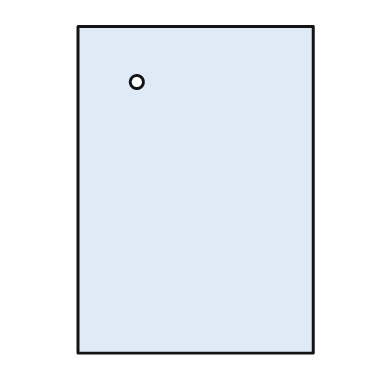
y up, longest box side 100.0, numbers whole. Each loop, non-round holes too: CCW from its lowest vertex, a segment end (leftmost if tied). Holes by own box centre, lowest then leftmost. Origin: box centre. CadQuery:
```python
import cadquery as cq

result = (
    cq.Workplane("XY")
    .moveTo(-36.0, -50.0)
    .lineTo(36.0, -50.0)
    .lineTo(36.0, 50.0)
    .lineTo(-36.0, 50.0)
    .close()
    .moveTo(-18.0, 33.0)
    .circle(2.0)
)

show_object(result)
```